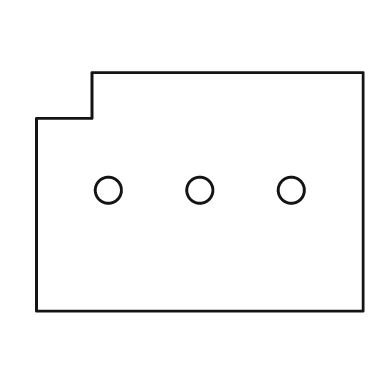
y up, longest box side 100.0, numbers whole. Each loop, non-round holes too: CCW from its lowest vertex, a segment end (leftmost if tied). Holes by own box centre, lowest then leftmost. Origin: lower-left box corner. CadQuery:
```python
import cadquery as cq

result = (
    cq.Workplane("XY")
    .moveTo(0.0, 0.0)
    .lineTo(100.0, 0.0)
    .lineTo(100.0, 73.0)
    .lineTo(17.0, 73.0)
    .lineTo(17.0, 59.0)
    .lineTo(0.0, 59.0)
    .close()
    .moveTo(22.0, 37.0)
    .circle(4.0)
    .moveTo(50.0, 37.0)
    .circle(4.0)
    .moveTo(78.0, 37.0)
    .circle(4.0)
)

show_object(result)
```